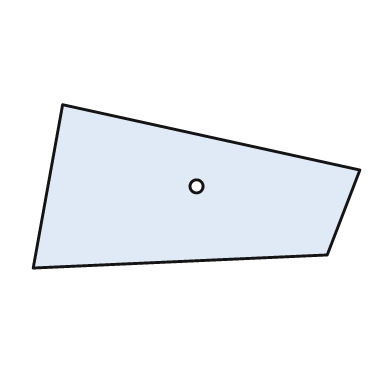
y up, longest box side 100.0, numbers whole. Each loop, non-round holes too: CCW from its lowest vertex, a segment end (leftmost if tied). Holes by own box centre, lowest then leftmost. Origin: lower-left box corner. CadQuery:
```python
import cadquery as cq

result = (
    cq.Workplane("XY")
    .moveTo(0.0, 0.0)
    .lineTo(90.0, 4.0)
    .lineTo(100.0, 30.0)
    .lineTo(9.0, 50.0)
    .close()
    .moveTo(50.0, 25.0)
    .circle(2.0)
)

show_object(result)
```